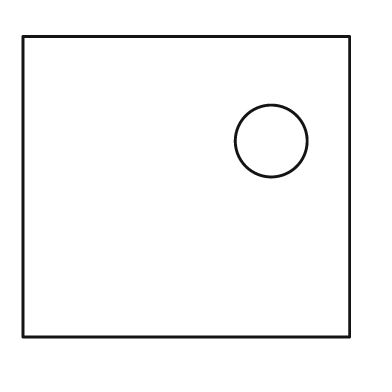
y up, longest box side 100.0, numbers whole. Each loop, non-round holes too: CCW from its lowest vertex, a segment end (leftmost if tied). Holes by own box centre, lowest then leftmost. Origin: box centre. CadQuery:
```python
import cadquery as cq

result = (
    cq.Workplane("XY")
    .moveTo(-50.0, -46.0)
    .lineTo(50.0, -46.0)
    .lineTo(50.0, 46.0)
    .lineTo(-50.0, 46.0)
    .close()
    .moveTo(26.0, 14.0)
    .circle(11.0)
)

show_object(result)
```